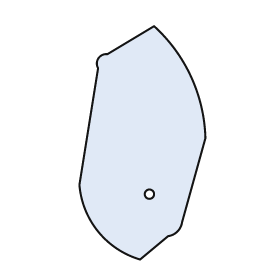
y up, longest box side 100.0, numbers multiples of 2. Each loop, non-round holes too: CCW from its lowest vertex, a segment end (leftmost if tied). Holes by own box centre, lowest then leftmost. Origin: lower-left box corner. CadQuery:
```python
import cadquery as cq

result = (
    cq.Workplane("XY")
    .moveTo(26.0, 0.0)
    .lineTo(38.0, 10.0)
    .threePointArc((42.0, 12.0), (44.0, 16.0))
    .lineTo(54.0, 52.0)
    .threePointArc((48.0, 78.0), (32.0, 100.0))
    .lineTo(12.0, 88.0)
    .threePointArc((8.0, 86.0), (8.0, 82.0))
    .lineTo(0.0, 32.0)
    .threePointArc((8.0, 12.0), (26.0, 0.0))
    .close()
    .moveTo(30.0, 28.0)
    .circle(2.0)
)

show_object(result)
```